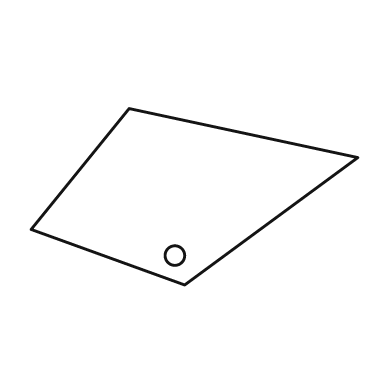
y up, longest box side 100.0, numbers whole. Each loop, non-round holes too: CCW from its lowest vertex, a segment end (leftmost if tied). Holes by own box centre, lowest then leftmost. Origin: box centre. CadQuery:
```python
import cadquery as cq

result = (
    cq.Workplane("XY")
    .moveTo(-3.0, -27.0)
    .lineTo(50.0, 12.0)
    .lineTo(-20.0, 27.0)
    .lineTo(-50.0, -10.0)
    .close()
    .moveTo(-6.0, -18.0)
    .circle(3.0)
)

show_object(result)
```